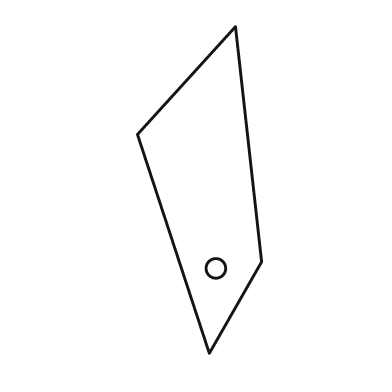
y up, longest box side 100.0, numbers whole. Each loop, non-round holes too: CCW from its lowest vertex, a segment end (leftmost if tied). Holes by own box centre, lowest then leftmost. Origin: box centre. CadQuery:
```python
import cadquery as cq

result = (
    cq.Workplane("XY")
    .moveTo(3.0, -50.0)
    .lineTo(19.0, -22.0)
    .lineTo(11.0, 50.0)
    .lineTo(-19.0, 17.0)
    .close()
    .moveTo(5.0, -24.0)
    .circle(3.0)
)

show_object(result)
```